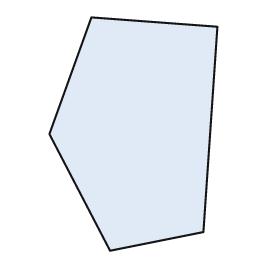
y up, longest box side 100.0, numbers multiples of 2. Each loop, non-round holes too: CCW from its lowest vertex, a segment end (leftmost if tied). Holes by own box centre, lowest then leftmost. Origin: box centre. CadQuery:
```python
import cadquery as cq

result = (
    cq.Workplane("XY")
    .moveTo(-10.0, -50.0)
    .lineTo(30.0, -42.0)
    .lineTo(36.0, 46.0)
    .lineTo(-18.0, 50.0)
    .lineTo(-36.0, 0.0)
    .close()
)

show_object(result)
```